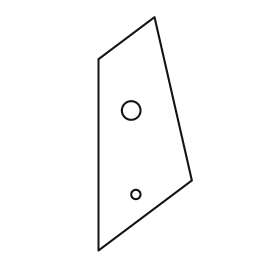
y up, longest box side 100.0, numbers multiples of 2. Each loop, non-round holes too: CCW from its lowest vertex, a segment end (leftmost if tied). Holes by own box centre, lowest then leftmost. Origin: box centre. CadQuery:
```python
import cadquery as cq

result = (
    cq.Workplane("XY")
    .moveTo(-20.0, -50.0)
    .lineTo(20.0, -20.0)
    .lineTo(4.0, 50.0)
    .lineTo(-20.0, 32.0)
    .close()
    .moveTo(-4.0, -26.0)
    .circle(2.0)
    .moveTo(-6.0, 10.0)
    .circle(4.0)
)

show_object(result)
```